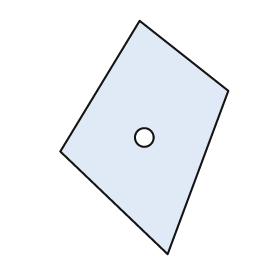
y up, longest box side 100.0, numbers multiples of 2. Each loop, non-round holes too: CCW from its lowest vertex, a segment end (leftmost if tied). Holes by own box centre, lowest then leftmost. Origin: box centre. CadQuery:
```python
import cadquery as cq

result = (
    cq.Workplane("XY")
    .moveTo(10.0, -50.0)
    .lineTo(36.0, 20.0)
    .lineTo(-2.0, 50.0)
    .lineTo(-36.0, -6.0)
    .close()
    .moveTo(0.0, 0.0)
    .circle(4.0)
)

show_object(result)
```